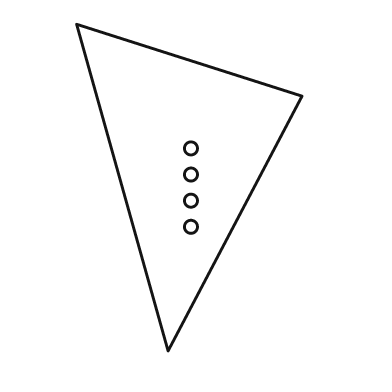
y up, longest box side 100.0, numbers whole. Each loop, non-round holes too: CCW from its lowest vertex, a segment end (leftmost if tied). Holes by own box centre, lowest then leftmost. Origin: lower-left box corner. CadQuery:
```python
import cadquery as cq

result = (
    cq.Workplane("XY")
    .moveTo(28.0, 0.0)
    .lineTo(69.0, 78.0)
    .lineTo(0.0, 100.0)
    .close()
    .moveTo(35.0, 38.0)
    .circle(2.0)
    .moveTo(35.0, 46.0)
    .circle(2.0)
    .moveTo(35.0, 54.0)
    .circle(2.0)
    .moveTo(35.0, 62.0)
    .circle(2.0)
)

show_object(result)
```